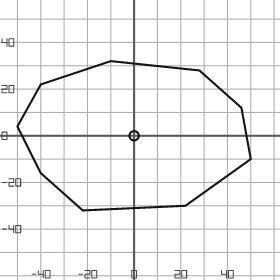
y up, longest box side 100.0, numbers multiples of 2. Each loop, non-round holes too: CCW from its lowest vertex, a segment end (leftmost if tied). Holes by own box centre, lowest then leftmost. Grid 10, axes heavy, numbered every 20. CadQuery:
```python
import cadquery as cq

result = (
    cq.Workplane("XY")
    .moveTo(-22.0, -32.0)
    .lineTo(22.0, -30.0)
    .lineTo(50.0, -10.0)
    .lineTo(46.0, 12.0)
    .lineTo(28.0, 28.0)
    .lineTo(-10.0, 32.0)
    .lineTo(-40.0, 22.0)
    .lineTo(-50.0, 4.0)
    .lineTo(-40.0, -16.0)
    .close()
    .moveTo(0.0, 0.0)
    .circle(2.0)
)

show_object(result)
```